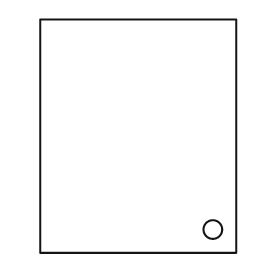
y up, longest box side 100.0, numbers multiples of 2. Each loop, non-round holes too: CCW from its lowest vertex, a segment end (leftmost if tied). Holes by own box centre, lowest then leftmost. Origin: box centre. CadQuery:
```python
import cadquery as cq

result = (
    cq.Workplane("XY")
    .moveTo(-42.0, -50.0)
    .lineTo(42.0, -50.0)
    .lineTo(42.0, 50.0)
    .lineTo(-42.0, 50.0)
    .close()
    .moveTo(32.0, -40.0)
    .circle(4.0)
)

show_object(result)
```